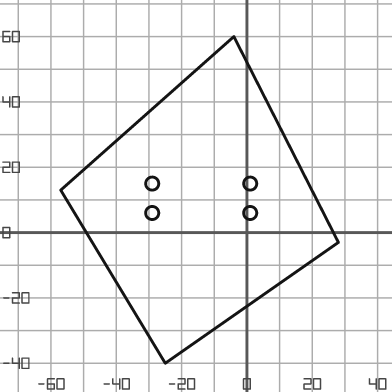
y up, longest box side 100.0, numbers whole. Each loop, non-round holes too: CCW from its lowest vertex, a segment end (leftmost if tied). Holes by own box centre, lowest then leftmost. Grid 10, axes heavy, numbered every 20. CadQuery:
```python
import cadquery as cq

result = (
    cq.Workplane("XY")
    .moveTo(-25.0, -40.0)
    .lineTo(28.0, -3.0)
    .lineTo(-4.0, 60.0)
    .lineTo(-57.0, 13.0)
    .close()
    .moveTo(-29.0, 6.0)
    .circle(2.0)
    .moveTo(1.0, 6.0)
    .circle(2.0)
    .moveTo(-29.0, 15.0)
    .circle(2.0)
    .moveTo(1.0, 15.0)
    .circle(2.0)
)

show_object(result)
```